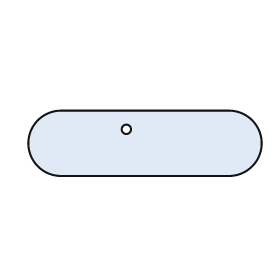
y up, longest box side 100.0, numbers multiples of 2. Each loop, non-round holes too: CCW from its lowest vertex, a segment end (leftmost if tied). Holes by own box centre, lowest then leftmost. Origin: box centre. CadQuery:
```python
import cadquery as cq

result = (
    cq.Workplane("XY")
    .moveTo(-36.0, -14.0)
    .lineTo(36.0, -14.0)
    .threePointArc((50.0, 0.0), (36.0, 14.0))
    .lineTo(-36.0, 14.0)
    .threePointArc((-50.0, 0.0), (-36.0, -14.0))
    .close()
    .moveTo(-8.0, 6.0)
    .circle(2.0)
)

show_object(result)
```